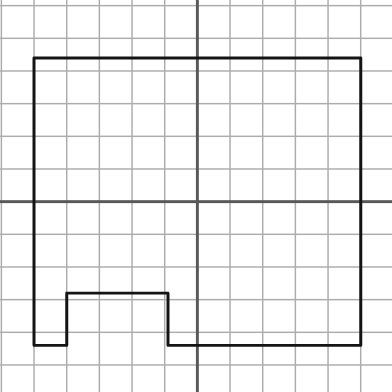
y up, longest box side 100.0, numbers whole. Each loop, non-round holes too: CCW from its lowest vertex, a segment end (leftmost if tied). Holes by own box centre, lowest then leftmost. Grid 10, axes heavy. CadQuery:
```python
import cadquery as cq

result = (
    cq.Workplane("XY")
    .moveTo(-50.0, -44.0)
    .lineTo(-40.0, -44.0)
    .lineTo(-40.0, -28.0)
    .lineTo(-9.0, -28.0)
    .lineTo(-9.0, -44.0)
    .lineTo(50.0, -44.0)
    .lineTo(50.0, 44.0)
    .lineTo(-50.0, 44.0)
    .close()
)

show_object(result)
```